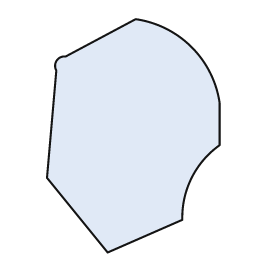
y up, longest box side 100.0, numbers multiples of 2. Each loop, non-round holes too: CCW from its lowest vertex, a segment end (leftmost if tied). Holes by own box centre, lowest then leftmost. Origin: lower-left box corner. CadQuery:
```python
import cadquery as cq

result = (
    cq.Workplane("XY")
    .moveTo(26.0, 0.0)
    .lineTo(58.0, 14.0)
    .threePointArc((62.0, 32.0), (74.0, 46.0))
    .lineTo(74.0, 64.0)
    .threePointArc((62.0, 88.0), (38.0, 100.0))
    .lineTo(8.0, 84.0)
    .threePointArc((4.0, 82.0), (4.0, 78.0))
    .lineTo(0.0, 32.0)
    .close()
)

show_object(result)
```